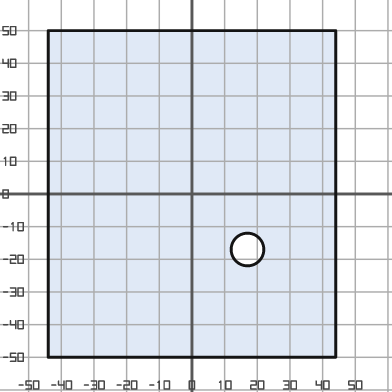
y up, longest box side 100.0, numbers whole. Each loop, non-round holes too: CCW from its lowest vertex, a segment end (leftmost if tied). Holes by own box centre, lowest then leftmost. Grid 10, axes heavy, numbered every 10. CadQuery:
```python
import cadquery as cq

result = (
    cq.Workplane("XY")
    .moveTo(-44.0, -50.0)
    .lineTo(44.0, -50.0)
    .lineTo(44.0, 50.0)
    .lineTo(-44.0, 50.0)
    .close()
    .moveTo(17.0, -17.0)
    .circle(5.0)
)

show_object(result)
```